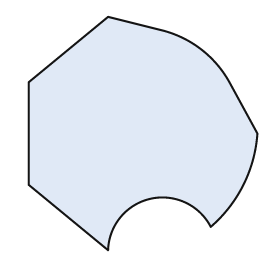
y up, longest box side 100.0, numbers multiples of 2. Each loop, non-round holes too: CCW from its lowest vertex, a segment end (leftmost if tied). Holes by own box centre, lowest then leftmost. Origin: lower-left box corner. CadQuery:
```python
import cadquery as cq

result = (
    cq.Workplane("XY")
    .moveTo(34.0, 0.0)
    .threePointArc((52.0, 22.0), (78.0, 10.0))
    .threePointArc((92.0, 28.0), (98.0, 50.0))
    .lineTo(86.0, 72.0)
    .threePointArc((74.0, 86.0), (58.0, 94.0))
    .lineTo(34.0, 100.0)
    .lineTo(0.0, 72.0)
    .lineTo(0.0, 28.0)
    .close()
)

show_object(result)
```